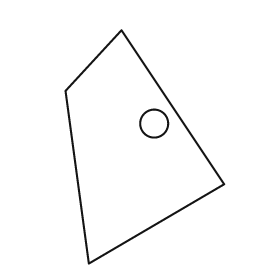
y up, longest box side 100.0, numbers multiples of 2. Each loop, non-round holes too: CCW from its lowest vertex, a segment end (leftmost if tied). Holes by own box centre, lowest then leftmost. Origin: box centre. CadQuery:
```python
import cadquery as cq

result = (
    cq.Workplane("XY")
    .moveTo(-24.0, -50.0)
    .lineTo(34.0, -16.0)
    .lineTo(-10.0, 50.0)
    .lineTo(-34.0, 24.0)
    .close()
    .moveTo(4.0, 10.0)
    .circle(6.0)
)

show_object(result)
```